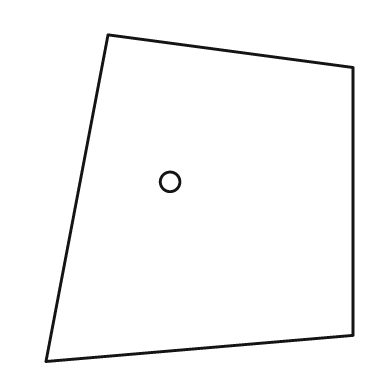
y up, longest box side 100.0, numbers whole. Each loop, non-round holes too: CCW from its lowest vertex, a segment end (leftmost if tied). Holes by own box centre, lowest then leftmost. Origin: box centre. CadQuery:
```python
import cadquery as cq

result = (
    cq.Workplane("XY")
    .moveTo(-47.0, -50.0)
    .lineTo(47.0, -42.0)
    .lineTo(47.0, 40.0)
    .lineTo(-28.0, 50.0)
    .close()
    .moveTo(-9.0, 5.0)
    .circle(3.0)
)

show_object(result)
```